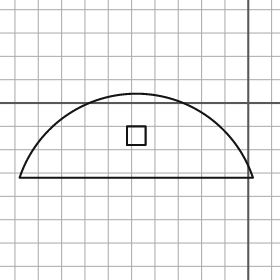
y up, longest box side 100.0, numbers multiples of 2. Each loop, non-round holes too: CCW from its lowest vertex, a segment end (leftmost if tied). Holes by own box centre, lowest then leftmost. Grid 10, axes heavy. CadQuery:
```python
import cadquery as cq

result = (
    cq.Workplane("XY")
    .moveTo(-98.0, -32.0)
    .lineTo(2.0, -32.0)
    .threePointArc((-48.0, 4.0), (-98.0, -32.0))
    .close()
    .moveTo(-52.0, -18.0)
    .lineTo(-44.0, -18.0)
    .lineTo(-44.0, -10.0)
    .lineTo(-52.0, -10.0)
    .close()
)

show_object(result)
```